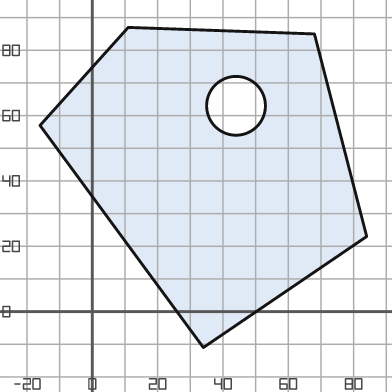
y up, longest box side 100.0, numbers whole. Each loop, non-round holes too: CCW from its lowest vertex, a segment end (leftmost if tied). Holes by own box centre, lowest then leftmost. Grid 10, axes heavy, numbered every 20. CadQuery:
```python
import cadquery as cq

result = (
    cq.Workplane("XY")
    .moveTo(34.0, -11.0)
    .lineTo(84.0, 23.0)
    .lineTo(68.0, 85.0)
    .lineTo(11.0, 87.0)
    .lineTo(-16.0, 57.0)
    .close()
    .moveTo(44.0, 63.0)
    .circle(9.0)
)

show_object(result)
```